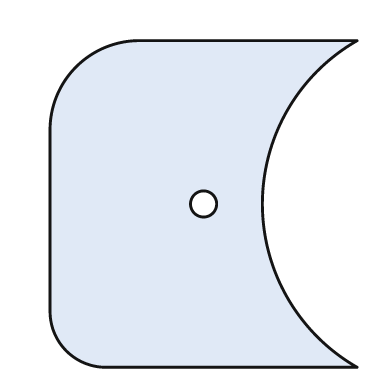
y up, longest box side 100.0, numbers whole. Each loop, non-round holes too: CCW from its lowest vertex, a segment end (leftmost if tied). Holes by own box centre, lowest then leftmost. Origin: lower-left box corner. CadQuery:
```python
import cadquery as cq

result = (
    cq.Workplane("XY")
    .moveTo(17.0, 0.0)
    .lineTo(94.0, 0.0)
    .threePointArc((65.0, 50.0), (94.0, 100.0))
    .lineTo(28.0, 100.0)
    .threePointArc((8.0, 92.0), (0.0, 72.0))
    .lineTo(0.0, 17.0)
    .threePointArc((5.0, 5.0), (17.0, 0.0))
    .close()
    .moveTo(47.0, 50.0)
    .circle(4.0)
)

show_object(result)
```